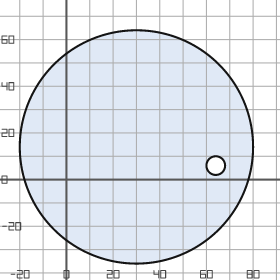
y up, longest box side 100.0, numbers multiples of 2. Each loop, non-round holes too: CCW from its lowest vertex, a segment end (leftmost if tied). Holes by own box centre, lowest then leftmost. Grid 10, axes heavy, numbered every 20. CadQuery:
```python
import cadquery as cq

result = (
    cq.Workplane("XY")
    .moveTo(30.0, 14.0)
    .circle(50.0)
    .moveTo(64.0, 6.0)
    .circle(4.0)
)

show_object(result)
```